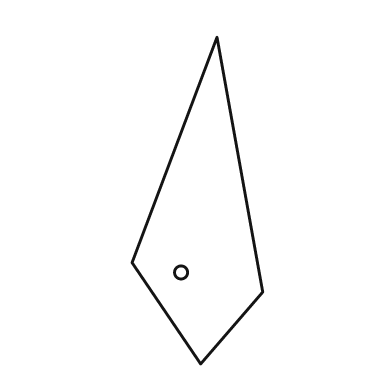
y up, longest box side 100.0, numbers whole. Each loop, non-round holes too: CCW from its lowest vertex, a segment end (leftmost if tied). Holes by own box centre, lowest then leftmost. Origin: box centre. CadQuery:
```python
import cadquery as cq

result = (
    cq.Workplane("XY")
    .moveTo(1.0, -50.0)
    .lineTo(20.0, -28.0)
    .lineTo(6.0, 50.0)
    .lineTo(-20.0, -19.0)
    .close()
    .moveTo(-5.0, -22.0)
    .circle(2.0)
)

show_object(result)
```